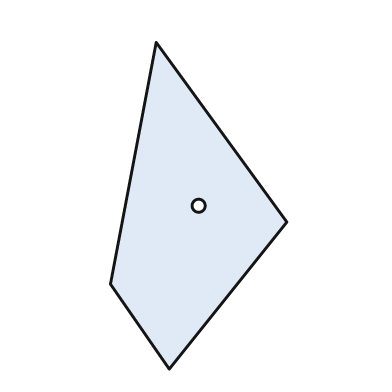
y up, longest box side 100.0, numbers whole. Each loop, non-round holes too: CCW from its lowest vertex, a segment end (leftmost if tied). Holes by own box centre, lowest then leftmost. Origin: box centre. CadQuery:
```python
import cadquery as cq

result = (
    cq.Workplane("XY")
    .moveTo(-9.0, -50.0)
    .lineTo(27.0, -5.0)
    .lineTo(-13.0, 50.0)
    .lineTo(-27.0, -24.0)
    .close()
    .moveTo(0.0, 0.0)
    .circle(2.0)
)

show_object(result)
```